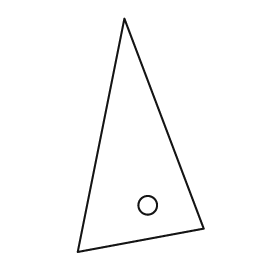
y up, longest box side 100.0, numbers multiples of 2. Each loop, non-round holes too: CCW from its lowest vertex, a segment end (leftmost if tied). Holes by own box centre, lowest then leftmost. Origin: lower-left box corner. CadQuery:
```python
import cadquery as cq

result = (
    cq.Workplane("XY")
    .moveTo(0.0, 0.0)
    .lineTo(54.0, 10.0)
    .lineTo(20.0, 100.0)
    .close()
    .moveTo(30.0, 20.0)
    .circle(4.0)
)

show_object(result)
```